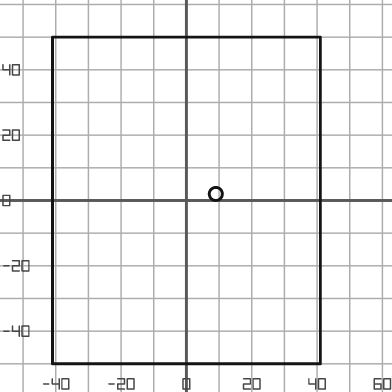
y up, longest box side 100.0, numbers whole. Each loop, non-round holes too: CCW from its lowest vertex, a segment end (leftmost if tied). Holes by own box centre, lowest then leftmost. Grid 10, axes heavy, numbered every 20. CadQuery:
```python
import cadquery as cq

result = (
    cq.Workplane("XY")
    .moveTo(-41.0, -50.0)
    .lineTo(41.0, -50.0)
    .lineTo(41.0, 50.0)
    .lineTo(-41.0, 50.0)
    .close()
    .moveTo(9.0, 2.0)
    .circle(2.0)
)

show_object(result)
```